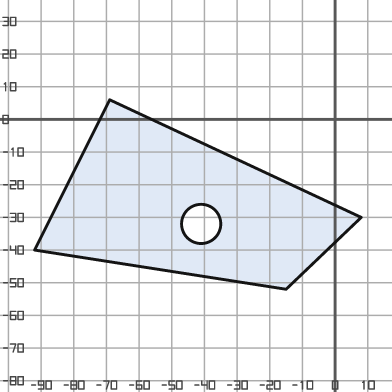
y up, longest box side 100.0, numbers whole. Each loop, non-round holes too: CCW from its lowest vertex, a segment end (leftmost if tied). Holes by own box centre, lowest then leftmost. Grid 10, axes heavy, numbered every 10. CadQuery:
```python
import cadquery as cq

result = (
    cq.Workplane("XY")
    .moveTo(-15.0, -52.0)
    .lineTo(8.0, -30.0)
    .lineTo(-69.0, 6.0)
    .lineTo(-92.0, -40.0)
    .close()
    .moveTo(-41.0, -32.0)
    .circle(6.0)
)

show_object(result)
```